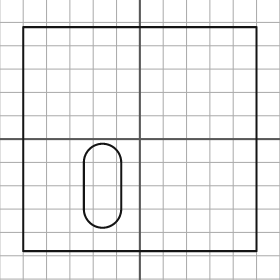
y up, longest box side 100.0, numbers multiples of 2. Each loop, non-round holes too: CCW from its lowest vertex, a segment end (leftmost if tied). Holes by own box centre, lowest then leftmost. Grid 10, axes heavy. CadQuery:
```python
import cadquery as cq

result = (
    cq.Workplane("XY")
    .moveTo(-50.0, -48.0)
    .lineTo(50.0, -48.0)
    .lineTo(50.0, 48.0)
    .lineTo(-50.0, 48.0)
    .close()
    .moveTo(-24.0, -30.0)
    .threePointArc((-16.0, -38.0), (-8.0, -30.0))
    .lineTo(-8.0, -10.0)
    .threePointArc((-16.0, -2.0), (-24.0, -10.0))
    .close()
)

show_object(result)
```